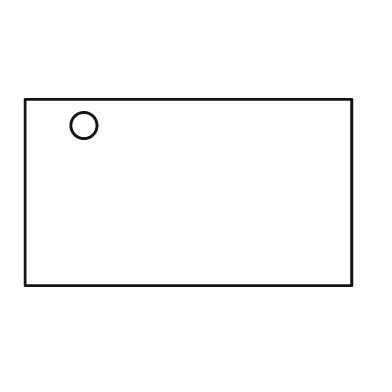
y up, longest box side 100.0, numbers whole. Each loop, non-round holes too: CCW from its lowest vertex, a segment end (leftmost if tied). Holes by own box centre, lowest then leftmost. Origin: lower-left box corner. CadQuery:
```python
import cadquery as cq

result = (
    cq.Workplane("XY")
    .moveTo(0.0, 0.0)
    .lineTo(100.0, 0.0)
    .lineTo(100.0, 57.0)
    .lineTo(0.0, 57.0)
    .close()
    .moveTo(18.0, 49.0)
    .circle(4.0)
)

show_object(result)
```